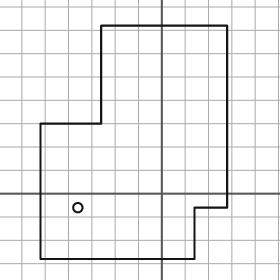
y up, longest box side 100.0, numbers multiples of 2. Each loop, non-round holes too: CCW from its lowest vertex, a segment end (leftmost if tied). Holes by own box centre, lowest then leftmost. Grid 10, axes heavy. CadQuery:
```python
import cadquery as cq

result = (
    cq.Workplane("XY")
    .moveTo(-52.0, -28.0)
    .lineTo(14.0, -28.0)
    .lineTo(14.0, -6.0)
    .lineTo(28.0, -6.0)
    .lineTo(28.0, 72.0)
    .lineTo(-26.0, 72.0)
    .lineTo(-26.0, 30.0)
    .lineTo(-52.0, 30.0)
    .close()
    .moveTo(-36.0, -6.0)
    .circle(2.0)
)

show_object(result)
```